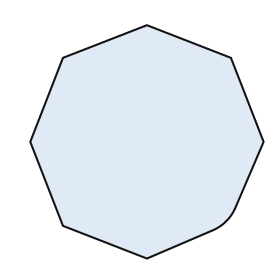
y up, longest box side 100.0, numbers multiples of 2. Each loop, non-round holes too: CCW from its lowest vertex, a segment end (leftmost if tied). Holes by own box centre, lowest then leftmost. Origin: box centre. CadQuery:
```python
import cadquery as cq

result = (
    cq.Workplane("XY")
    .moveTo(0.0, -50.0)
    .lineTo(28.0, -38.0)
    .threePointArc((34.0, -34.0), (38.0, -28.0))
    .lineTo(50.0, 0.0)
    .lineTo(36.0, 36.0)
    .lineTo(0.0, 50.0)
    .lineTo(-36.0, 36.0)
    .lineTo(-50.0, 0.0)
    .lineTo(-36.0, -36.0)
    .close()
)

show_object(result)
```